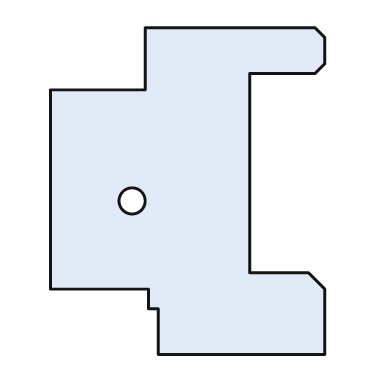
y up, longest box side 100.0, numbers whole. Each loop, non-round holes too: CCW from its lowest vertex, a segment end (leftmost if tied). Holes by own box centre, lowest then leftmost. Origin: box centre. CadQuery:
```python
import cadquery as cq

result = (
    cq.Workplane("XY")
    .moveTo(-9.0, -50.0)
    .lineTo(42.0, -50.0)
    .lineTo(42.0, -30.0)
    .lineTo(37.0, -25.0)
    .lineTo(19.0, -25.0)
    .lineTo(19.0, 36.0)
    .lineTo(39.0, 36.0)
    .lineTo(42.0, 39.0)
    .lineTo(42.0, 47.0)
    .lineTo(39.0, 50.0)
    .lineTo(-13.0, 50.0)
    .lineTo(-13.0, 31.0)
    .lineTo(-42.0, 31.0)
    .lineTo(-42.0, -30.0)
    .lineTo(-12.0, -30.0)
    .lineTo(-12.0, -36.0)
    .lineTo(-9.0, -36.0)
    .close()
    .moveTo(-17.0, -3.0)
    .circle(4.0)
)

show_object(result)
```